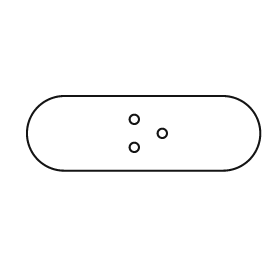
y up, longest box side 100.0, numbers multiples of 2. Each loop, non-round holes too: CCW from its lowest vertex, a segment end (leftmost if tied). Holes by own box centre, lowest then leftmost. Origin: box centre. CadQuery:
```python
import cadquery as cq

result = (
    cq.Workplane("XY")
    .moveTo(-34.0, -16.0)
    .lineTo(34.0, -16.0)
    .threePointArc((50.0, 0.0), (34.0, 16.0))
    .lineTo(-34.0, 16.0)
    .threePointArc((-50.0, 0.0), (-34.0, -16.0))
    .close()
    .moveTo(-4.0, -6.0)
    .circle(2.0)
    .moveTo(8.0, 0.0)
    .circle(2.0)
    .moveTo(-4.0, 6.0)
    .circle(2.0)
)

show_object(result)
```